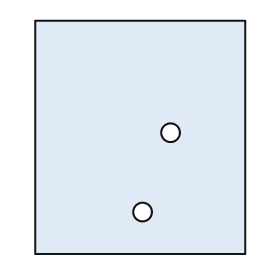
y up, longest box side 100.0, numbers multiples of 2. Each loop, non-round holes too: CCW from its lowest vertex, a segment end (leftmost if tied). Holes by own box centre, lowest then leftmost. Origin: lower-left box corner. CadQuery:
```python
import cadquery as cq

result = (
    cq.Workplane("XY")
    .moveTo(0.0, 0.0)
    .lineTo(90.0, 0.0)
    .lineTo(90.0, 100.0)
    .lineTo(0.0, 100.0)
    .close()
    .moveTo(46.0, 18.0)
    .circle(4.0)
    .moveTo(58.0, 52.0)
    .circle(4.0)
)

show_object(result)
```